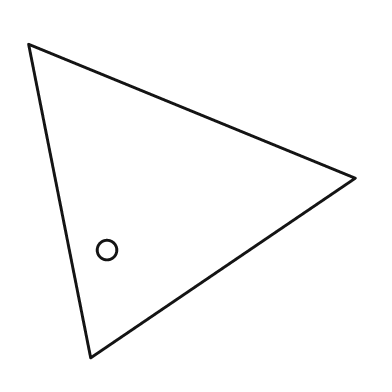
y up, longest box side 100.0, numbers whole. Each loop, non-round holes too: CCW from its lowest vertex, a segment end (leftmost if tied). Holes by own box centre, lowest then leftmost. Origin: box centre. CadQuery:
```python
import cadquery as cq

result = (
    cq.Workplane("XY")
    .moveTo(-31.0, -48.0)
    .lineTo(50.0, 7.0)
    .lineTo(-50.0, 48.0)
    .close()
    .moveTo(-26.0, -15.0)
    .circle(3.0)
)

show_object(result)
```